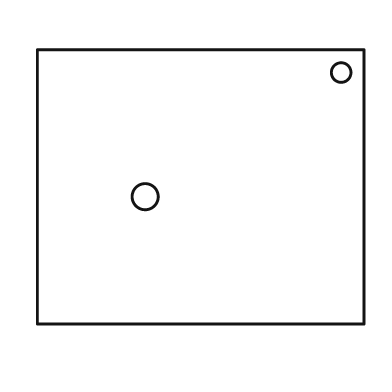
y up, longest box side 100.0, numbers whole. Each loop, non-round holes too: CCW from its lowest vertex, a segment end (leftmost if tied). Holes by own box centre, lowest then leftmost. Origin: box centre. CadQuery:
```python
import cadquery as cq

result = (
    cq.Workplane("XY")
    .moveTo(-50.0, -42.0)
    .lineTo(50.0, -42.0)
    .lineTo(50.0, 42.0)
    .lineTo(-50.0, 42.0)
    .close()
    .moveTo(-17.0, -3.0)
    .circle(4.0)
    .moveTo(43.0, 35.0)
    .circle(3.0)
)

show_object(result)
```